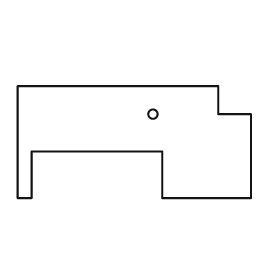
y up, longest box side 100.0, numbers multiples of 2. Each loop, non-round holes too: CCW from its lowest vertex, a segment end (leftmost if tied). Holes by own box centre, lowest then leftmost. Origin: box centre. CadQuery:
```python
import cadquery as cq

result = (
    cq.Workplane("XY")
    .moveTo(-50.0, -24.0)
    .lineTo(-44.0, -24.0)
    .lineTo(-44.0, -4.0)
    .lineTo(12.0, -4.0)
    .lineTo(12.0, -24.0)
    .lineTo(50.0, -24.0)
    .lineTo(50.0, 12.0)
    .lineTo(36.0, 12.0)
    .lineTo(36.0, 24.0)
    .lineTo(-50.0, 24.0)
    .close()
    .moveTo(8.0, 12.0)
    .circle(2.0)
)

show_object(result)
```